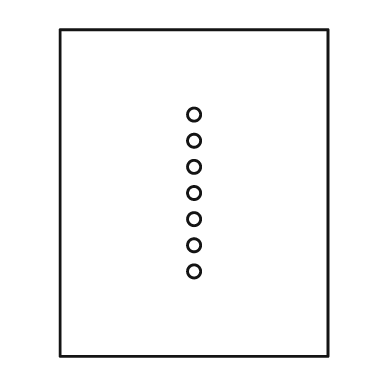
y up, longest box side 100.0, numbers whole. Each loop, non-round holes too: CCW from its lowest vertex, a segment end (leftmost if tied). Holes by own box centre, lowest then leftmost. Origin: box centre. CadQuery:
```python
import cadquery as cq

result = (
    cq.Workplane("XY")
    .moveTo(-41.0, -50.0)
    .lineTo(41.0, -50.0)
    .lineTo(41.0, 50.0)
    .lineTo(-41.0, 50.0)
    .close()
    .moveTo(0.0, -24.0)
    .circle(2.0)
    .moveTo(0.0, -16.0)
    .circle(2.0)
    .moveTo(0.0, -8.0)
    .circle(2.0)
    .moveTo(0.0, 0.0)
    .circle(2.0)
    .moveTo(0.0, 8.0)
    .circle(2.0)
    .moveTo(0.0, 16.0)
    .circle(2.0)
    .moveTo(0.0, 24.0)
    .circle(2.0)
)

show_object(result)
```